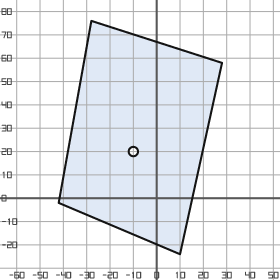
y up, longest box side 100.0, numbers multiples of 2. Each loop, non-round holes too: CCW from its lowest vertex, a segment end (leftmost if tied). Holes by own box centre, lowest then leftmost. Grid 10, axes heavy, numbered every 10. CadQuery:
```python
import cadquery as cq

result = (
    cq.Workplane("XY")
    .moveTo(10.0, -24.0)
    .lineTo(28.0, 58.0)
    .lineTo(-28.0, 76.0)
    .lineTo(-42.0, -2.0)
    .close()
    .moveTo(-10.0, 20.0)
    .circle(2.0)
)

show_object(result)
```